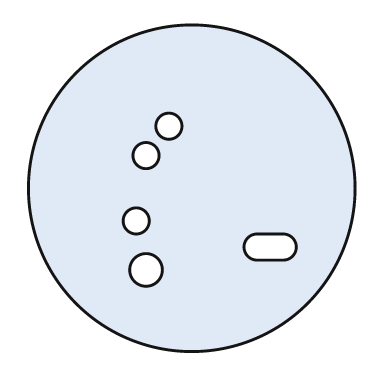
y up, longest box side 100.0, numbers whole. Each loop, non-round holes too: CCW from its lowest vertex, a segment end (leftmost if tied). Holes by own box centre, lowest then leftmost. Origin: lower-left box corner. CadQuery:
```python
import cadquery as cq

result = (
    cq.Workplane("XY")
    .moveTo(50.0, 50.0)
    .circle(50.0)
    .moveTo(36.0, 25.0)
    .circle(5.0)
    .moveTo(70.0, 28.0)
    .lineTo(78.0, 28.0)
    .threePointArc((82.0, 32.0), (78.0, 36.0))
    .lineTo(70.0, 36.0)
    .threePointArc((66.0, 32.0), (70.0, 28.0))
    .close()
    .moveTo(33.0, 40.0)
    .circle(4.0)
    .moveTo(36.0, 60.0)
    .circle(4.0)
    .moveTo(43.0, 69.0)
    .circle(4.0)
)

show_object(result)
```